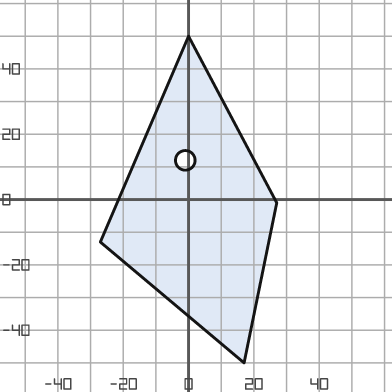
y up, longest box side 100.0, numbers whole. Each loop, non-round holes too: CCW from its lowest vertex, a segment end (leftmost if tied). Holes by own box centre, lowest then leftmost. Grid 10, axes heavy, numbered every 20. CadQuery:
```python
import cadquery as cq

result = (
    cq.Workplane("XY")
    .moveTo(17.0, -50.0)
    .lineTo(27.0, -1.0)
    .lineTo(0.0, 50.0)
    .lineTo(-27.0, -13.0)
    .close()
    .moveTo(-1.0, 12.0)
    .circle(3.0)
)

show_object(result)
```